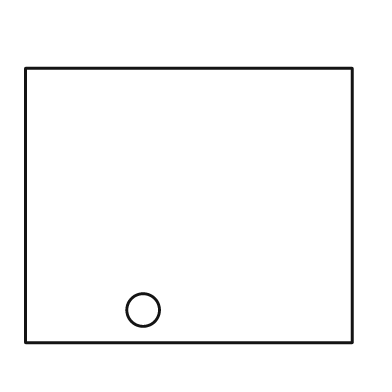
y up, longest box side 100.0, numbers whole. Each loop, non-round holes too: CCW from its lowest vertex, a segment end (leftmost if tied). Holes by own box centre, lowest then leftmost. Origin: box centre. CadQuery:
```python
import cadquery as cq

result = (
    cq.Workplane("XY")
    .moveTo(-50.0, -42.0)
    .lineTo(50.0, -42.0)
    .lineTo(50.0, 42.0)
    .lineTo(-50.0, 42.0)
    .close()
    .moveTo(-14.0, -32.0)
    .circle(5.0)
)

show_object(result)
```